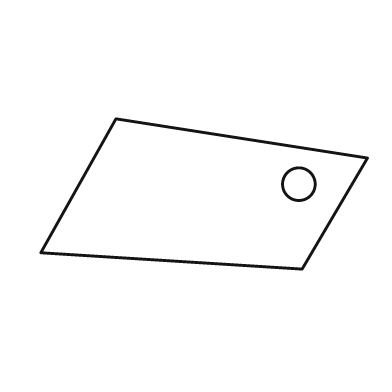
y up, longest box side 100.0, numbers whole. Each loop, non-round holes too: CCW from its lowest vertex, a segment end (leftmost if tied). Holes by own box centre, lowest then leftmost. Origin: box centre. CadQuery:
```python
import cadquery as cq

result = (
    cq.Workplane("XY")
    .moveTo(30.0, -23.0)
    .lineTo(50.0, 11.0)
    .lineTo(-27.0, 23.0)
    .lineTo(-50.0, -18.0)
    .close()
    .moveTo(29.0, 3.0)
    .circle(5.0)
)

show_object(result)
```